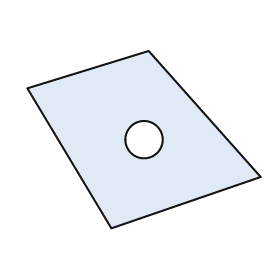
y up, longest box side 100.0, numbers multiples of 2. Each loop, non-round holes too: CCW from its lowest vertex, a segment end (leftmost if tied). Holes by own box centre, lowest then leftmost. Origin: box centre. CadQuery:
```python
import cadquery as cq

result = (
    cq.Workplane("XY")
    .moveTo(-14.0, -38.0)
    .lineTo(50.0, -16.0)
    .lineTo(2.0, 38.0)
    .lineTo(-50.0, 22.0)
    .close()
    .moveTo(0.0, 0.0)
    .circle(8.0)
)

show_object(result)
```